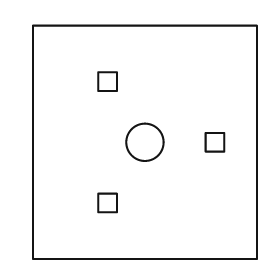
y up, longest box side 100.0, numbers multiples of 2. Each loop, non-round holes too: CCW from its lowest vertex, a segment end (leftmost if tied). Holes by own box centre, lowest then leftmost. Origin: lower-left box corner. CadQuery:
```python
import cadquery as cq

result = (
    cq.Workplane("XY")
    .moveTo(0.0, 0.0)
    .lineTo(96.0, 0.0)
    .lineTo(96.0, 100.0)
    .lineTo(0.0, 100.0)
    .close()
    .moveTo(28.0, 20.0)
    .lineTo(36.0, 20.0)
    .lineTo(36.0, 28.0)
    .lineTo(28.0, 28.0)
    .close()
    .moveTo(48.0, 50.0)
    .circle(8.0)
    .moveTo(74.0, 46.0)
    .lineTo(82.0, 46.0)
    .lineTo(82.0, 54.0)
    .lineTo(74.0, 54.0)
    .close()
    .moveTo(28.0, 72.0)
    .lineTo(36.0, 72.0)
    .lineTo(36.0, 80.0)
    .lineTo(28.0, 80.0)
    .close()
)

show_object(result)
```